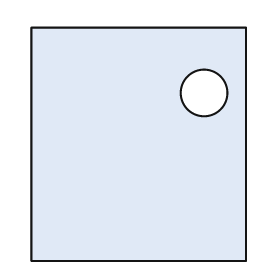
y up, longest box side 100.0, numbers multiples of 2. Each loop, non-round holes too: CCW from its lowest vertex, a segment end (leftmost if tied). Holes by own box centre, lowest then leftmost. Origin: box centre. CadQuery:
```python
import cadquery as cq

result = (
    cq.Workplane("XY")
    .moveTo(-46.0, -50.0)
    .lineTo(46.0, -50.0)
    .lineTo(46.0, 50.0)
    .lineTo(-46.0, 50.0)
    .close()
    .moveTo(28.0, 22.0)
    .circle(10.0)
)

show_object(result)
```